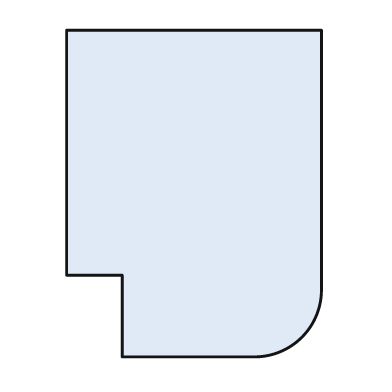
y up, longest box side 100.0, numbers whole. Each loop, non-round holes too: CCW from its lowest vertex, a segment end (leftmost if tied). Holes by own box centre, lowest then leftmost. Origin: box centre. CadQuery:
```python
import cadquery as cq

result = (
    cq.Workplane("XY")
    .moveTo(-22.0, -50.0)
    .lineTo(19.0, -50.0)
    .threePointArc((33.0, -44.0), (39.0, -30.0))
    .lineTo(39.0, 50.0)
    .lineTo(-39.0, 50.0)
    .lineTo(-39.0, -25.0)
    .lineTo(-22.0, -25.0)
    .close()
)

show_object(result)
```